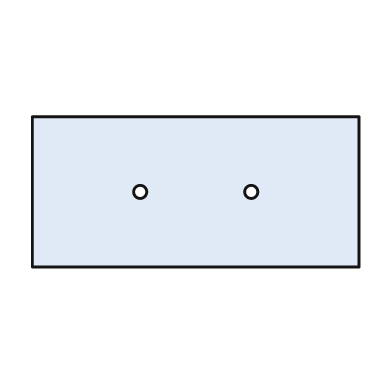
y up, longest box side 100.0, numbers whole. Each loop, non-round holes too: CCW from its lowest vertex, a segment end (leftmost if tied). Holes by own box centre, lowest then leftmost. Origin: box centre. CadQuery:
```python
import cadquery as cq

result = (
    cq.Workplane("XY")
    .moveTo(-50.0, -23.0)
    .lineTo(50.0, -23.0)
    .lineTo(50.0, 23.0)
    .lineTo(-50.0, 23.0)
    .close()
    .moveTo(-17.0, 0.0)
    .circle(2.0)
    .moveTo(17.0, 0.0)
    .circle(2.0)
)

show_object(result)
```